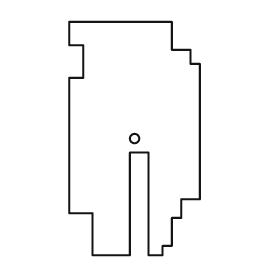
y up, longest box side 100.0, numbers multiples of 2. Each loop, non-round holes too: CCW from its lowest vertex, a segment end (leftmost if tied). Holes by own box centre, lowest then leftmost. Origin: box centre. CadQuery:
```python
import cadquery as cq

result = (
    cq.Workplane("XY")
    .moveTo(-18.0, -50.0)
    .lineTo(-2.0, -50.0)
    .lineTo(-2.0, -6.0)
    .lineTo(6.0, -6.0)
    .lineTo(6.0, -50.0)
    .lineTo(12.0, -50.0)
    .lineTo(12.0, -46.0)
    .lineTo(16.0, -46.0)
    .lineTo(16.0, -34.0)
    .lineTo(20.0, -34.0)
    .lineTo(20.0, -26.0)
    .lineTo(28.0, -26.0)
    .lineTo(28.0, 32.0)
    .lineTo(24.0, 32.0)
    .lineTo(24.0, 38.0)
    .lineTo(16.0, 38.0)
    .lineTo(16.0, 50.0)
    .lineTo(-28.0, 50.0)
    .lineTo(-28.0, 40.0)
    .lineTo(-22.0, 40.0)
    .lineTo(-22.0, 26.0)
    .lineTo(-28.0, 26.0)
    .lineTo(-28.0, -32.0)
    .lineTo(-18.0, -32.0)
    .close()
    .moveTo(0.0, 0.0)
    .circle(2.0)
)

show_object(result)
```